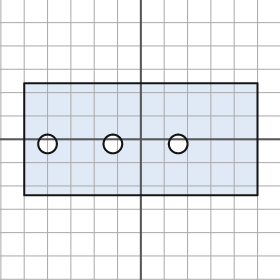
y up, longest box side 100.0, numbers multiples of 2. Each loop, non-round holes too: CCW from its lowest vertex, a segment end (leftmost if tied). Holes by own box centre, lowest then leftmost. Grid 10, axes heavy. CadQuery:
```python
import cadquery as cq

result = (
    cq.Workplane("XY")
    .moveTo(-50.0, -24.0)
    .lineTo(50.0, -24.0)
    .lineTo(50.0, 24.0)
    .lineTo(-50.0, 24.0)
    .close()
    .moveTo(-40.0, -2.0)
    .circle(4.0)
    .moveTo(-12.0, -2.0)
    .circle(4.0)
    .moveTo(16.0, -2.0)
    .circle(4.0)
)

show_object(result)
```